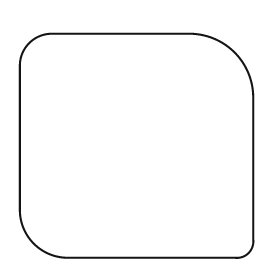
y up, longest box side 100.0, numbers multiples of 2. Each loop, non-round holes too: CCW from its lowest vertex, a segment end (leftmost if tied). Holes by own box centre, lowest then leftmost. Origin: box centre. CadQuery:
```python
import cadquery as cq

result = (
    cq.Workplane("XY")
    .moveTo(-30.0, -48.0)
    .lineTo(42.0, -48.0)
    .threePointArc((48.0, -46.0), (50.0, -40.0))
    .lineTo(50.0, 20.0)
    .threePointArc((42.0, 40.0), (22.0, 48.0))
    .lineTo(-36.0, 48.0)
    .threePointArc((-46.0, 44.0), (-50.0, 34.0))
    .lineTo(-50.0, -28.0)
    .threePointArc((-44.0, -42.0), (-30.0, -48.0))
    .close()
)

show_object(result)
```